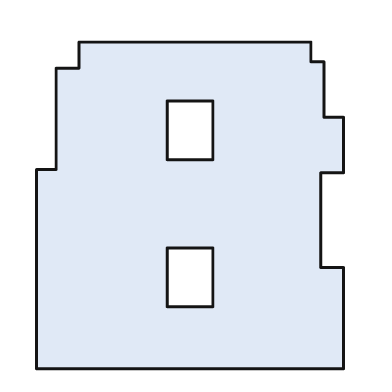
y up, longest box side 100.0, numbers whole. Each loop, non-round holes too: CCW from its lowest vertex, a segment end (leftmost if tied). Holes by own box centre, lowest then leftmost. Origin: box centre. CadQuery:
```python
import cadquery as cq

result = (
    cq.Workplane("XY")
    .moveTo(-47.0, -50.0)
    .lineTo(47.0, -50.0)
    .lineTo(47.0, -19.0)
    .lineTo(40.0, -19.0)
    .lineTo(40.0, 10.0)
    .lineTo(47.0, 10.0)
    .lineTo(47.0, 27.0)
    .lineTo(41.0, 27.0)
    .lineTo(41.0, 44.0)
    .lineTo(37.0, 44.0)
    .lineTo(37.0, 50.0)
    .lineTo(-34.0, 50.0)
    .lineTo(-34.0, 42.0)
    .lineTo(-41.0, 42.0)
    .lineTo(-41.0, 11.0)
    .lineTo(-47.0, 11.0)
    .close()
    .moveTo(-7.0, -31.0)
    .lineTo(7.0, -31.0)
    .lineTo(7.0, -13.0)
    .lineTo(-7.0, -13.0)
    .close()
    .moveTo(-7.0, 14.0)
    .lineTo(7.0, 14.0)
    .lineTo(7.0, 32.0)
    .lineTo(-7.0, 32.0)
    .close()
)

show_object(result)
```